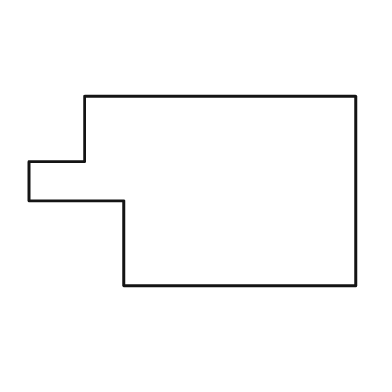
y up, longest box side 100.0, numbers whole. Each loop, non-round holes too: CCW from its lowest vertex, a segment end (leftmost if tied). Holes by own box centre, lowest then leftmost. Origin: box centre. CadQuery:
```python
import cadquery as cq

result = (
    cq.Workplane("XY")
    .moveTo(-21.0, -29.0)
    .lineTo(50.0, -29.0)
    .lineTo(50.0, 29.0)
    .lineTo(-33.0, 29.0)
    .lineTo(-33.0, 9.0)
    .lineTo(-50.0, 9.0)
    .lineTo(-50.0, -3.0)
    .lineTo(-21.0, -3.0)
    .close()
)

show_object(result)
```